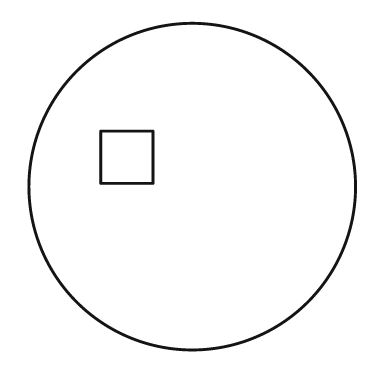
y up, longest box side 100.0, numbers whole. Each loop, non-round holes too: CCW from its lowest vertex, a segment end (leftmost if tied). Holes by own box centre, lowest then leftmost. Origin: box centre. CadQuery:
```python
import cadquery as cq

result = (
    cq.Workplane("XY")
    .moveTo(0.0, 0.0)
    .circle(50.0)
    .moveTo(-28.0, 1.0)
    .lineTo(-12.0, 1.0)
    .lineTo(-12.0, 17.0)
    .lineTo(-28.0, 17.0)
    .close()
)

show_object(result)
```